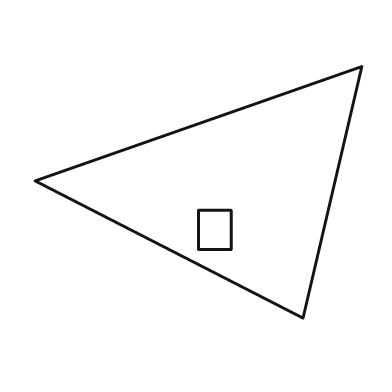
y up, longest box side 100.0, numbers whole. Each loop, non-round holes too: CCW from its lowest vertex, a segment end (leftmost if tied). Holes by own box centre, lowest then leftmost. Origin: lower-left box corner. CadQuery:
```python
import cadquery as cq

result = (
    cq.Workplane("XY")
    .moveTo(82.0, 0.0)
    .lineTo(100.0, 77.0)
    .lineTo(0.0, 42.0)
    .close()
    .moveTo(50.0, 21.0)
    .lineTo(60.0, 21.0)
    .lineTo(60.0, 33.0)
    .lineTo(50.0, 33.0)
    .close()
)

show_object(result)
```